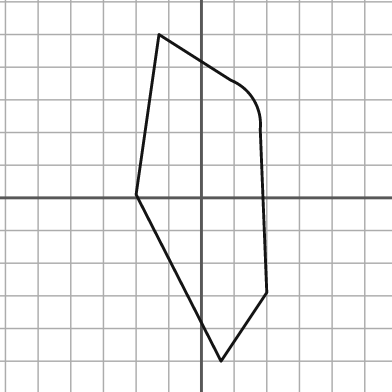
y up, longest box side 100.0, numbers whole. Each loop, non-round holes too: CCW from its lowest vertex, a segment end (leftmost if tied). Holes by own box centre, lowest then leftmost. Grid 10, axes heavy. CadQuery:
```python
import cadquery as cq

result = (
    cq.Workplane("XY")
    .moveTo(6.0, -50.0)
    .lineTo(20.0, -29.0)
    .lineTo(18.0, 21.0)
    .threePointArc((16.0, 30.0), (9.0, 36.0))
    .lineTo(-13.0, 50.0)
    .lineTo(-20.0, 1.0)
    .close()
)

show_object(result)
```